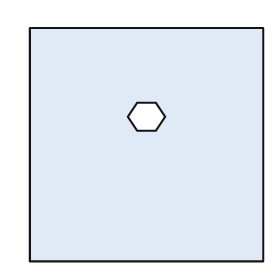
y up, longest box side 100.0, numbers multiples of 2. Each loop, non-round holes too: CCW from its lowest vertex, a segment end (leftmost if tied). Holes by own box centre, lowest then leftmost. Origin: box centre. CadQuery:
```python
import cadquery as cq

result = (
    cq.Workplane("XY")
    .moveTo(-50.0, -50.0)
    .lineTo(50.0, -50.0)
    .lineTo(50.0, 50.0)
    .lineTo(-50.0, 50.0)
    .close()
    .moveTo(-4.0, 6.0)
    .lineTo(4.0, 6.0)
    .lineTo(8.0, 12.0)
    .lineTo(4.0, 18.0)
    .lineTo(-4.0, 18.0)
    .lineTo(-8.0, 12.0)
    .close()
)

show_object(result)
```